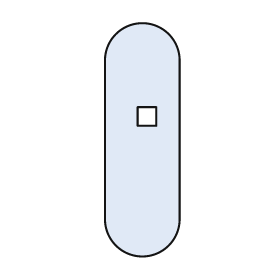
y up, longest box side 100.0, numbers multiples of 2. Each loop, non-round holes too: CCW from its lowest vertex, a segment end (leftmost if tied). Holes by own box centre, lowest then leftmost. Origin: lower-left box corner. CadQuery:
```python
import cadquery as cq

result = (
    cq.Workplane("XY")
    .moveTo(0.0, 16.0)
    .threePointArc((16.0, 0.0), (32.0, 16.0))
    .lineTo(32.0, 84.0)
    .threePointArc((16.0, 100.0), (0.0, 84.0))
    .close()
    .moveTo(14.0, 56.0)
    .lineTo(22.0, 56.0)
    .lineTo(22.0, 64.0)
    .lineTo(14.0, 64.0)
    .close()
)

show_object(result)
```